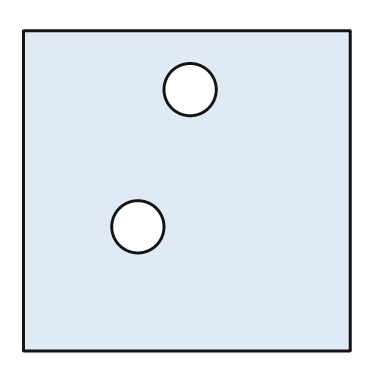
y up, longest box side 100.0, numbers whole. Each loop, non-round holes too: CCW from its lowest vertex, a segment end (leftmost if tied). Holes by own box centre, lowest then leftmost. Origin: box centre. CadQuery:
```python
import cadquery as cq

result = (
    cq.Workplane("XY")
    .moveTo(-50.0, -49.0)
    .lineTo(50.0, -49.0)
    .lineTo(50.0, 49.0)
    .lineTo(-50.0, 49.0)
    .close()
    .moveTo(-15.0, -11.0)
    .circle(8.0)
    .moveTo(1.0, 31.0)
    .circle(8.0)
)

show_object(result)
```